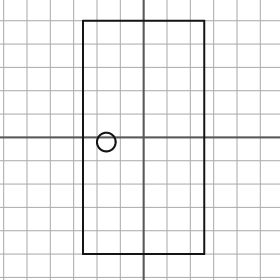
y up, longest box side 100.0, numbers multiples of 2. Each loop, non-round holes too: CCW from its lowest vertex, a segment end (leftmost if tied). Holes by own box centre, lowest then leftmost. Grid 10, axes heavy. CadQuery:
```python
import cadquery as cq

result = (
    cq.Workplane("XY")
    .moveTo(-26.0, -50.0)
    .lineTo(26.0, -50.0)
    .lineTo(26.0, 50.0)
    .lineTo(-26.0, 50.0)
    .close()
    .moveTo(-16.0, -2.0)
    .circle(4.0)
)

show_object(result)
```